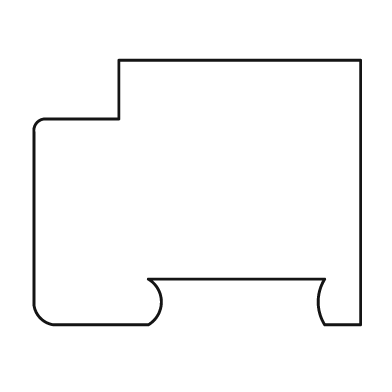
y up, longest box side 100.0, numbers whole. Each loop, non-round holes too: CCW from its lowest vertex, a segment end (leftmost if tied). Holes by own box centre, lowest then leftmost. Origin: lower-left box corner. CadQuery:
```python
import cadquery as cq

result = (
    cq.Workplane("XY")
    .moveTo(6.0, 0.0)
    .lineTo(35.0, 0.0)
    .threePointArc((39.0, 7.0), (35.0, 14.0))
    .lineTo(89.0, 14.0)
    .threePointArc((87.0, 7.0), (89.0, 0.0))
    .lineTo(100.0, 0.0)
    .lineTo(100.0, 81.0)
    .lineTo(26.0, 81.0)
    .lineTo(26.0, 63.0)
    .lineTo(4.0, 63.0)
    .threePointArc((1.0, 62.0), (0.0, 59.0))
    .lineTo(0.0, 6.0)
    .threePointArc((2.0, 2.0), (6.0, 0.0))
    .close()
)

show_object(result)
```